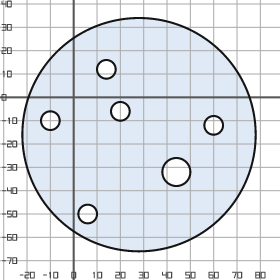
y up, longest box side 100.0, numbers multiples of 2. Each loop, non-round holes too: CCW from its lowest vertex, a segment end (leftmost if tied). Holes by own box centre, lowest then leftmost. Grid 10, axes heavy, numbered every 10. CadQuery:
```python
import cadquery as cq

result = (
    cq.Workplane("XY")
    .moveTo(28.0, -16.0)
    .circle(50.0)
    .moveTo(6.0, -50.0)
    .circle(4.0)
    .moveTo(44.0, -32.0)
    .circle(6.0)
    .moveTo(60.0, -12.0)
    .circle(4.0)
    .moveTo(-10.0, -10.0)
    .circle(4.0)
    .moveTo(20.0, -6.0)
    .circle(4.0)
    .moveTo(14.0, 12.0)
    .circle(4.0)
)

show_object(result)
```